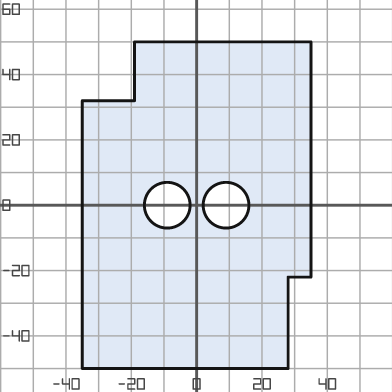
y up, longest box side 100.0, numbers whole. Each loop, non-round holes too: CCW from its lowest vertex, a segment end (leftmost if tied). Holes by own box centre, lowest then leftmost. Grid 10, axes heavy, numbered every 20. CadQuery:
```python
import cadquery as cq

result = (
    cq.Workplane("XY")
    .moveTo(-35.0, -50.0)
    .lineTo(28.0, -50.0)
    .lineTo(28.0, -22.0)
    .lineTo(35.0, -22.0)
    .lineTo(35.0, 50.0)
    .lineTo(-19.0, 50.0)
    .lineTo(-19.0, 32.0)
    .lineTo(-35.0, 32.0)
    .close()
    .moveTo(-9.0, 0.0)
    .circle(7.0)
    .moveTo(9.0, 0.0)
    .circle(7.0)
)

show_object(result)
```